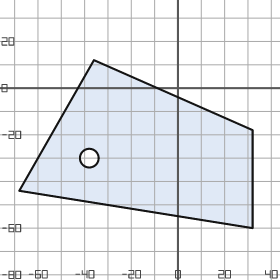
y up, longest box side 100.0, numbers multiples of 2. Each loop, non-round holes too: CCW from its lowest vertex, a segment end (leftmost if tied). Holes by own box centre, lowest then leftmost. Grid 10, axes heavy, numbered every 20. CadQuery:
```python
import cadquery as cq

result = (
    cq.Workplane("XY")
    .moveTo(32.0, -60.0)
    .lineTo(32.0, -18.0)
    .lineTo(-36.0, 12.0)
    .lineTo(-68.0, -44.0)
    .close()
    .moveTo(-38.0, -30.0)
    .circle(4.0)
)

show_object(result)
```